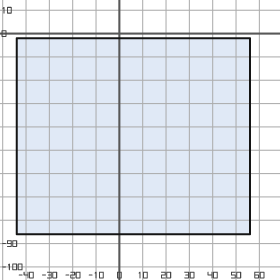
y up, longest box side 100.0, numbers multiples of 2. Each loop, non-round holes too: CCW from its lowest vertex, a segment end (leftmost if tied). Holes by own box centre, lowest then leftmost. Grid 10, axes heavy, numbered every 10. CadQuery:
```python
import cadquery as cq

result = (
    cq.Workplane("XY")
    .moveTo(-44.0, -86.0)
    .lineTo(56.0, -86.0)
    .lineTo(56.0, -2.0)
    .lineTo(-44.0, -2.0)
    .close()
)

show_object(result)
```